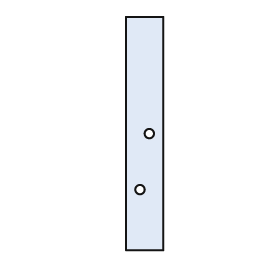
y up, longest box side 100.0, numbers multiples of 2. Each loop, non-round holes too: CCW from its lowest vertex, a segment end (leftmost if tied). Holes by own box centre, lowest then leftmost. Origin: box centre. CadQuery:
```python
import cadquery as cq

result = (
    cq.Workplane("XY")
    .moveTo(-8.0, -50.0)
    .lineTo(8.0, -50.0)
    .lineTo(8.0, 50.0)
    .lineTo(-8.0, 50.0)
    .close()
    .moveTo(-2.0, -24.0)
    .circle(2.0)
    .moveTo(2.0, 0.0)
    .circle(2.0)
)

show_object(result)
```